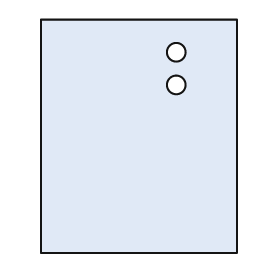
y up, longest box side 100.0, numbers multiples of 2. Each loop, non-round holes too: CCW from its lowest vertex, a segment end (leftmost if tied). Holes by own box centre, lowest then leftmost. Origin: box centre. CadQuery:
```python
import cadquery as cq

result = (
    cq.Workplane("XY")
    .moveTo(-42.0, -50.0)
    .lineTo(42.0, -50.0)
    .lineTo(42.0, 50.0)
    .lineTo(-42.0, 50.0)
    .close()
    .moveTo(16.0, 22.0)
    .circle(4.0)
    .moveTo(16.0, 36.0)
    .circle(4.0)
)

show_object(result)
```